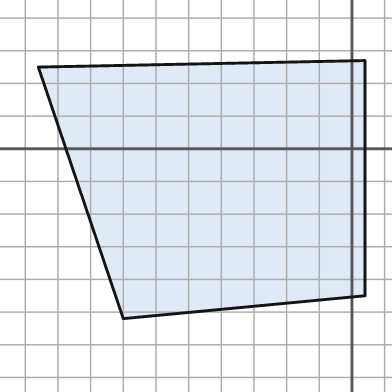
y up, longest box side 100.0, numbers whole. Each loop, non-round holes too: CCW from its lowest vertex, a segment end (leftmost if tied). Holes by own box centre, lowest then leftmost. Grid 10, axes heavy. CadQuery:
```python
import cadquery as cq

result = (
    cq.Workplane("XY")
    .moveTo(-70.0, -52.0)
    .lineTo(4.0, -45.0)
    .lineTo(4.0, 27.0)
    .lineTo(-96.0, 25.0)
    .close()
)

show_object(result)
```